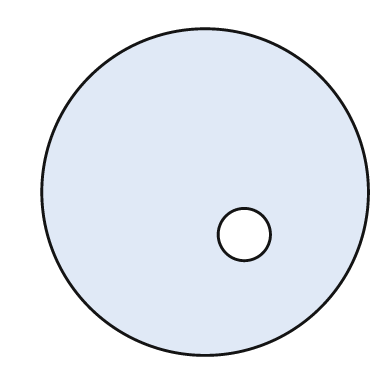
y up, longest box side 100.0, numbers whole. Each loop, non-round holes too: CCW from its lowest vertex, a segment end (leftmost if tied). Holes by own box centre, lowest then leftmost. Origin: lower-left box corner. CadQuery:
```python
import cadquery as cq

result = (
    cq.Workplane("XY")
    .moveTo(50.0, 50.0)
    .circle(50.0)
    .moveTo(62.0, 37.0)
    .circle(8.0)
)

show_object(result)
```